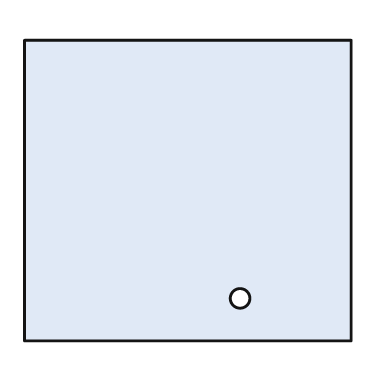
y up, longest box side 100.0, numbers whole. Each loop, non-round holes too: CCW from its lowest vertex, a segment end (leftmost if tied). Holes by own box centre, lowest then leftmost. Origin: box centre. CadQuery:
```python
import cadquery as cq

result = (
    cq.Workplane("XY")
    .moveTo(-50.0, -46.0)
    .lineTo(50.0, -46.0)
    .lineTo(50.0, 46.0)
    .lineTo(-50.0, 46.0)
    .close()
    .moveTo(16.0, -33.0)
    .circle(3.0)
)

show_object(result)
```